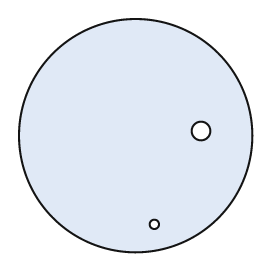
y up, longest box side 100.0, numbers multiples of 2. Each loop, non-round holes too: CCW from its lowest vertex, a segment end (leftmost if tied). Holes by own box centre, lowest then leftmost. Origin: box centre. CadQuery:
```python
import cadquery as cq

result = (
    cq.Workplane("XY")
    .moveTo(0.0, 0.0)
    .circle(50.0)
    .moveTo(8.0, -38.0)
    .circle(2.0)
    .moveTo(28.0, 2.0)
    .circle(4.0)
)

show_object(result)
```